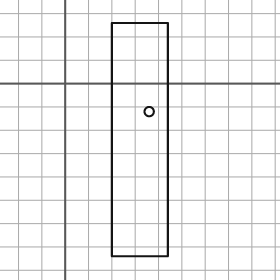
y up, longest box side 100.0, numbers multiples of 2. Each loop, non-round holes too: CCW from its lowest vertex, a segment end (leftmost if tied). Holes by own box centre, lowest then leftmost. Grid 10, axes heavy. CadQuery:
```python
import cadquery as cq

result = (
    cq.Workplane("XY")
    .moveTo(20.0, -74.0)
    .lineTo(44.0, -74.0)
    .lineTo(44.0, 26.0)
    .lineTo(20.0, 26.0)
    .close()
    .moveTo(36.0, -12.0)
    .circle(2.0)
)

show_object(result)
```